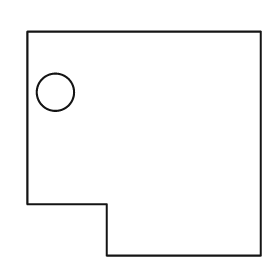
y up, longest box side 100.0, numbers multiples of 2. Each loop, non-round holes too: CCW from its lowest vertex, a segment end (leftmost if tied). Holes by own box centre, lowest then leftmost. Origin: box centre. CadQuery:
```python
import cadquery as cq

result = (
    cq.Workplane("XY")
    .moveTo(-16.0, -48.0)
    .lineTo(50.0, -48.0)
    .lineTo(50.0, 48.0)
    .lineTo(-50.0, 48.0)
    .lineTo(-50.0, -26.0)
    .lineTo(-16.0, -26.0)
    .close()
    .moveTo(-38.0, 22.0)
    .circle(8.0)
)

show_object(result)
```